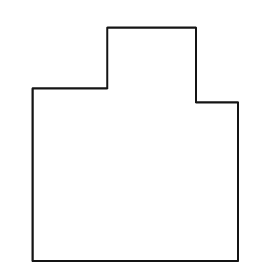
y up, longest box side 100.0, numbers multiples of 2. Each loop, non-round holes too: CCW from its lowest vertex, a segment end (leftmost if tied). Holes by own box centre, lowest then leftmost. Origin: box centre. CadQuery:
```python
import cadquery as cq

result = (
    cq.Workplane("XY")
    .moveTo(-44.0, -50.0)
    .lineTo(44.0, -50.0)
    .lineTo(44.0, 18.0)
    .lineTo(26.0, 18.0)
    .lineTo(26.0, 50.0)
    .lineTo(-12.0, 50.0)
    .lineTo(-12.0, 24.0)
    .lineTo(-44.0, 24.0)
    .close()
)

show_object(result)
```